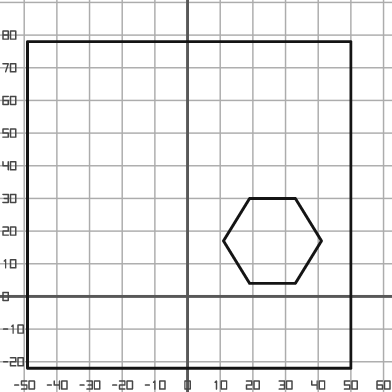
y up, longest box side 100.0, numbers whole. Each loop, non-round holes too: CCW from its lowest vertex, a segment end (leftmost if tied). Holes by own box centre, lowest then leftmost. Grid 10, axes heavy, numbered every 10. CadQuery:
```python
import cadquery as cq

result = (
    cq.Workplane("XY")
    .moveTo(-49.0, -22.0)
    .lineTo(50.0, -22.0)
    .lineTo(50.0, 78.0)
    .lineTo(-49.0, 78.0)
    .close()
    .moveTo(19.0, 4.0)
    .lineTo(33.0, 4.0)
    .lineTo(41.0, 17.0)
    .lineTo(33.0, 30.0)
    .lineTo(19.0, 30.0)
    .lineTo(11.0, 17.0)
    .close()
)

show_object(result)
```